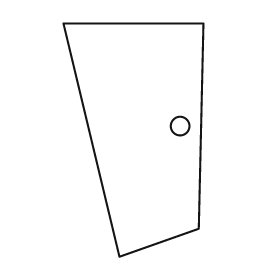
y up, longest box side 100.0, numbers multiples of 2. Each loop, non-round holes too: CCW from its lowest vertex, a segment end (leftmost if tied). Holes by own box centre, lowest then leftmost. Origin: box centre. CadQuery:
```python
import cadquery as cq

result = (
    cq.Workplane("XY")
    .moveTo(-6.0, -50.0)
    .lineTo(28.0, -38.0)
    .lineTo(30.0, 50.0)
    .lineTo(-30.0, 50.0)
    .close()
    .moveTo(20.0, 6.0)
    .circle(4.0)
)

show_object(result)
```